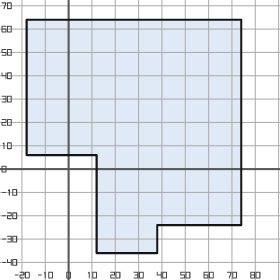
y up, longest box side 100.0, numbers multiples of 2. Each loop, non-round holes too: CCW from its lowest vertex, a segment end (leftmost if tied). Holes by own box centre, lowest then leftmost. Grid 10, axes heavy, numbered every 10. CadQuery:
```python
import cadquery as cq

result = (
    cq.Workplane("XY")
    .moveTo(12.0, -36.0)
    .lineTo(38.0, -36.0)
    .lineTo(38.0, -24.0)
    .lineTo(74.0, -24.0)
    .lineTo(74.0, 64.0)
    .lineTo(-18.0, 64.0)
    .lineTo(-18.0, 6.0)
    .lineTo(12.0, 6.0)
    .close()
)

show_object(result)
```